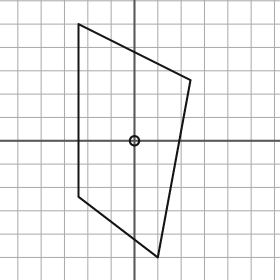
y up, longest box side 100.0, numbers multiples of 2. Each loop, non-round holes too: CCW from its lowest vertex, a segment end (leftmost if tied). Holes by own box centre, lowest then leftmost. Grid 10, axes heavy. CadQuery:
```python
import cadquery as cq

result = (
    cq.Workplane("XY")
    .moveTo(10.0, -50.0)
    .lineTo(24.0, 26.0)
    .lineTo(-24.0, 50.0)
    .lineTo(-24.0, -24.0)
    .close()
    .moveTo(0.0, 0.0)
    .circle(2.0)
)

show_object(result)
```